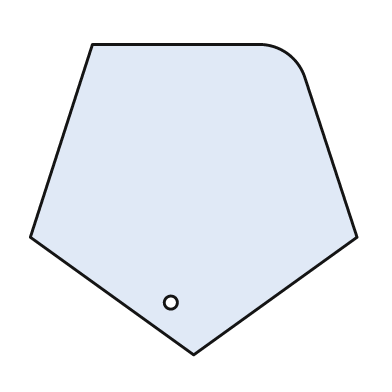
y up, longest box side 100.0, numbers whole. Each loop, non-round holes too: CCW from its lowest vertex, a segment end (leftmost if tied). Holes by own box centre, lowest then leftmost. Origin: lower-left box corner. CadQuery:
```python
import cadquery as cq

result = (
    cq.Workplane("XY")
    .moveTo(50.0, 0.0)
    .lineTo(100.0, 36.0)
    .lineTo(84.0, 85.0)
    .threePointArc((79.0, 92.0), (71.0, 95.0))
    .lineTo(19.0, 95.0)
    .lineTo(0.0, 36.0)
    .close()
    .moveTo(43.0, 16.0)
    .circle(2.0)
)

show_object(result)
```